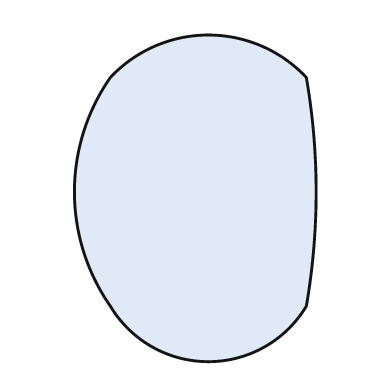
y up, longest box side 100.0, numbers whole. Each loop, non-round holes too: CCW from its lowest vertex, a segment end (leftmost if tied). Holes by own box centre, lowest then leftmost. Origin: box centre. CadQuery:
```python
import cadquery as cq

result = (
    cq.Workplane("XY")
    .moveTo(-26.0, -33.0)
    .threePointArc((4.0, -50.0), (34.0, -33.0))
    .threePointArc((37.0, 2.0), (34.0, 37.0))
    .threePointArc((4.0, 50.0), (-26.0, 37.0))
    .threePointArc((-37.0, 2.0), (-26.0, -33.0))
    .close()
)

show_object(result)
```